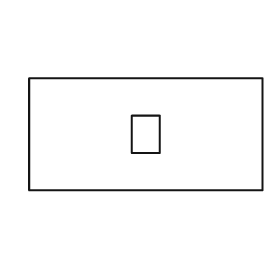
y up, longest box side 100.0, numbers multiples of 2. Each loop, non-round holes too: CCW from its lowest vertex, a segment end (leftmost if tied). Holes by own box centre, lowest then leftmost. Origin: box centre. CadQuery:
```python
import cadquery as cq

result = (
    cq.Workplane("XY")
    .moveTo(-50.0, -24.0)
    .lineTo(50.0, -24.0)
    .lineTo(50.0, 24.0)
    .lineTo(-50.0, 24.0)
    .close()
    .moveTo(-6.0, -8.0)
    .lineTo(6.0, -8.0)
    .lineTo(6.0, 8.0)
    .lineTo(-6.0, 8.0)
    .close()
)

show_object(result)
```